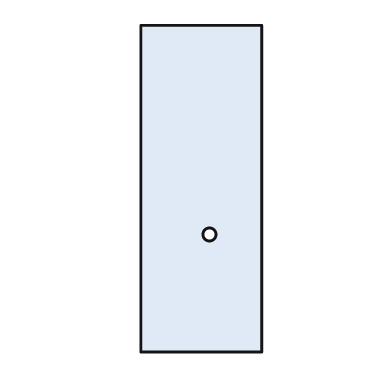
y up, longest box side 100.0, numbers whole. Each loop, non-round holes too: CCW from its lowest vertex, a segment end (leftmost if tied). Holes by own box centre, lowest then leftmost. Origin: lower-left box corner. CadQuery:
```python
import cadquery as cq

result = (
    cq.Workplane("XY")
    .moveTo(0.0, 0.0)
    .lineTo(37.0, 0.0)
    .lineTo(37.0, 100.0)
    .lineTo(0.0, 100.0)
    .close()
    .moveTo(21.0, 36.0)
    .circle(2.0)
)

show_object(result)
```